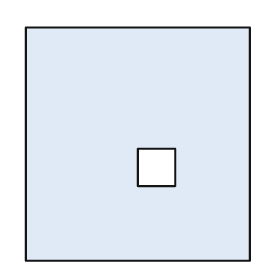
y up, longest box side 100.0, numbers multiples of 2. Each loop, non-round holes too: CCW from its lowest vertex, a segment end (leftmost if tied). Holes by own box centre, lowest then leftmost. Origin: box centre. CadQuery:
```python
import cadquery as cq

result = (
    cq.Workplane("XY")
    .moveTo(-48.0, -50.0)
    .lineTo(48.0, -50.0)
    .lineTo(48.0, 50.0)
    .lineTo(-48.0, 50.0)
    .close()
    .moveTo(0.0, -18.0)
    .lineTo(16.0, -18.0)
    .lineTo(16.0, -2.0)
    .lineTo(0.0, -2.0)
    .close()
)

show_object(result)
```